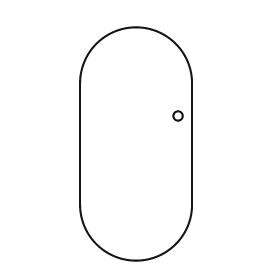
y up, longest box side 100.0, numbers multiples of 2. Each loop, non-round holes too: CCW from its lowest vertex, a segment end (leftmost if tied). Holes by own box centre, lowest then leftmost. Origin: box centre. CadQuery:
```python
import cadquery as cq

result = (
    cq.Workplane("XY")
    .moveTo(-24.0, -26.0)
    .threePointArc((0.0, -50.0), (24.0, -26.0))
    .lineTo(24.0, 26.0)
    .threePointArc((0.0, 50.0), (-24.0, 26.0))
    .close()
    .moveTo(18.0, 12.0)
    .circle(2.0)
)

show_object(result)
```